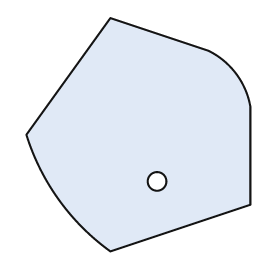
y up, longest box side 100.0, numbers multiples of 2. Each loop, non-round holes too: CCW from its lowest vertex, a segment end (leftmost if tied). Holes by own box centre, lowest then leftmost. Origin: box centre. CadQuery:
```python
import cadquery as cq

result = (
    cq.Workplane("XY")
    .moveTo(-12.0, -50.0)
    .lineTo(48.0, -30.0)
    .lineTo(48.0, 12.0)
    .threePointArc((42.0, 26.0), (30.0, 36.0))
    .lineTo(-12.0, 50.0)
    .lineTo(-48.0, 0.0)
    .threePointArc((-34.0, -28.0), (-12.0, -50.0))
    .close()
    .moveTo(8.0, -20.0)
    .circle(4.0)
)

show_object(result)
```